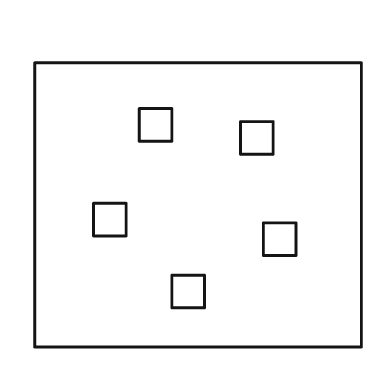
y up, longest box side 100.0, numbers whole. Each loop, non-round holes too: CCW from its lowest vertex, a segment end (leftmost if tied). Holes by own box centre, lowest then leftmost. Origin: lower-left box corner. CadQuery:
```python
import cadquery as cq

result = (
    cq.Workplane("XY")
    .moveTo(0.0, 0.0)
    .lineTo(100.0, 0.0)
    .lineTo(100.0, 87.0)
    .lineTo(0.0, 87.0)
    .close()
    .moveTo(42.0, 12.0)
    .lineTo(52.0, 12.0)
    .lineTo(52.0, 22.0)
    .lineTo(42.0, 22.0)
    .close()
    .moveTo(70.0, 28.0)
    .lineTo(80.0, 28.0)
    .lineTo(80.0, 38.0)
    .lineTo(70.0, 38.0)
    .close()
    .moveTo(18.0, 34.0)
    .lineTo(28.0, 34.0)
    .lineTo(28.0, 44.0)
    .lineTo(18.0, 44.0)
    .close()
    .moveTo(63.0, 59.0)
    .lineTo(73.0, 59.0)
    .lineTo(73.0, 69.0)
    .lineTo(63.0, 69.0)
    .close()
    .moveTo(32.0, 63.0)
    .lineTo(42.0, 63.0)
    .lineTo(42.0, 73.0)
    .lineTo(32.0, 73.0)
    .close()
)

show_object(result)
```